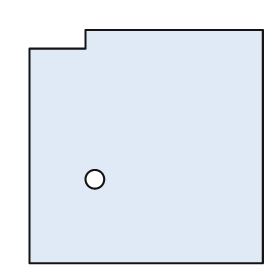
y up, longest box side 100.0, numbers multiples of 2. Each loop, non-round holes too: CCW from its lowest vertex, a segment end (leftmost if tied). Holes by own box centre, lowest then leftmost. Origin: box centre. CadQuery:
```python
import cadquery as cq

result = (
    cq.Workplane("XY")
    .moveTo(-50.0, -50.0)
    .lineTo(50.0, -50.0)
    .lineTo(50.0, 50.0)
    .lineTo(-26.0, 50.0)
    .lineTo(-26.0, 42.0)
    .lineTo(-50.0, 42.0)
    .close()
    .moveTo(-22.0, -14.0)
    .circle(4.0)
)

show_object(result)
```